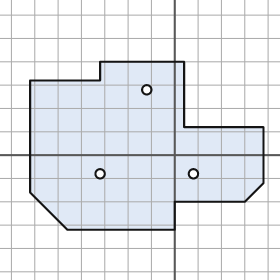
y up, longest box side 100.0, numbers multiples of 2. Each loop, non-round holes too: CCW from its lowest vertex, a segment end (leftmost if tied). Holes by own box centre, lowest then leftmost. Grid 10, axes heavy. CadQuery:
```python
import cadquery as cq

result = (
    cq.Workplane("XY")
    .moveTo(-46.0, -32.0)
    .lineTo(0.0, -32.0)
    .lineTo(0.0, -20.0)
    .lineTo(30.0, -20.0)
    .lineTo(38.0, -12.0)
    .lineTo(38.0, 12.0)
    .lineTo(4.0, 12.0)
    .lineTo(4.0, 40.0)
    .lineTo(-32.0, 40.0)
    .lineTo(-32.0, 32.0)
    .lineTo(-62.0, 32.0)
    .lineTo(-62.0, -16.0)
    .close()
    .moveTo(-32.0, -8.0)
    .circle(2.0)
    .moveTo(8.0, -8.0)
    .circle(2.0)
    .moveTo(-12.0, 28.0)
    .circle(2.0)
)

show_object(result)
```